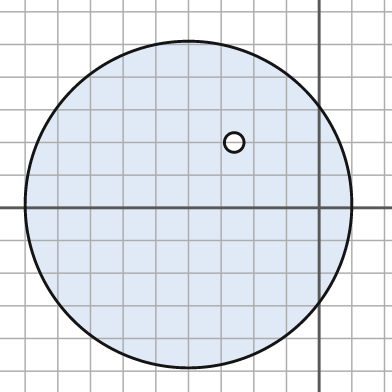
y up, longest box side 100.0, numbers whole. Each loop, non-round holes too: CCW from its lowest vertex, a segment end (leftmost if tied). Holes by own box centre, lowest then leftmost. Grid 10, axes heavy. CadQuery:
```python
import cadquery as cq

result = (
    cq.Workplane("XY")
    .moveTo(-40.0, 1.0)
    .circle(50.0)
    .moveTo(-26.0, 20.0)
    .circle(3.0)
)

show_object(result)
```